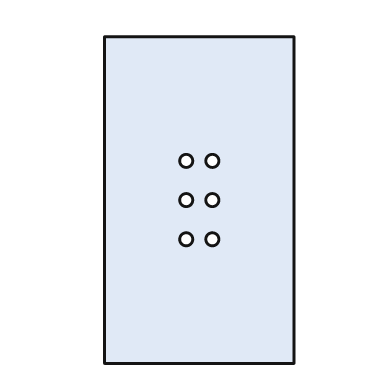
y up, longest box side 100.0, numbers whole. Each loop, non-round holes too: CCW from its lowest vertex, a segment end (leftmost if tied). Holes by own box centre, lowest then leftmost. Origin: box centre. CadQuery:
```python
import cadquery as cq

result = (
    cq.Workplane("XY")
    .moveTo(-29.0, -50.0)
    .lineTo(29.0, -50.0)
    .lineTo(29.0, 50.0)
    .lineTo(-29.0, 50.0)
    .close()
    .moveTo(-4.0, -12.0)
    .circle(2.0)
    .moveTo(4.0, -12.0)
    .circle(2.0)
    .moveTo(-4.0, 0.0)
    .circle(2.0)
    .moveTo(4.0, 0.0)
    .circle(2.0)
    .moveTo(-4.0, 12.0)
    .circle(2.0)
    .moveTo(4.0, 12.0)
    .circle(2.0)
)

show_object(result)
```